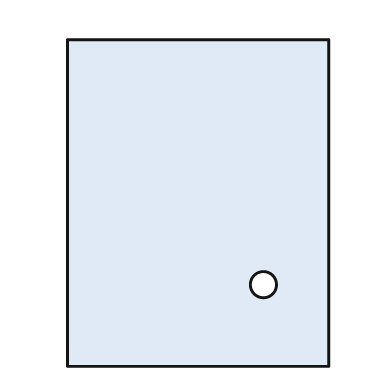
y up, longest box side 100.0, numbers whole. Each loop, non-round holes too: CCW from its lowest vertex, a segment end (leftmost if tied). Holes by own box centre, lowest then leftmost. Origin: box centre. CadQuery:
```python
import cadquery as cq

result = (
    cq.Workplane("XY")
    .moveTo(-40.0, -50.0)
    .lineTo(40.0, -50.0)
    .lineTo(40.0, 50.0)
    .lineTo(-40.0, 50.0)
    .close()
    .moveTo(20.0, -25.0)
    .circle(4.0)
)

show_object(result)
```